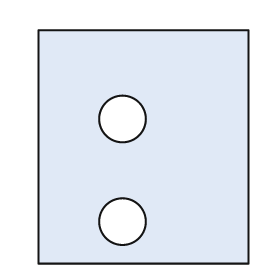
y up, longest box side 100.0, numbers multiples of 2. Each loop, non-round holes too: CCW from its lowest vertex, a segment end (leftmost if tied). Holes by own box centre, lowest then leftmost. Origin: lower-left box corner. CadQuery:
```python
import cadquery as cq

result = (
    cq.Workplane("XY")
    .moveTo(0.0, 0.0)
    .lineTo(90.0, 0.0)
    .lineTo(90.0, 100.0)
    .lineTo(0.0, 100.0)
    .close()
    .moveTo(36.0, 18.0)
    .circle(10.0)
    .moveTo(36.0, 62.0)
    .circle(10.0)
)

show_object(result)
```